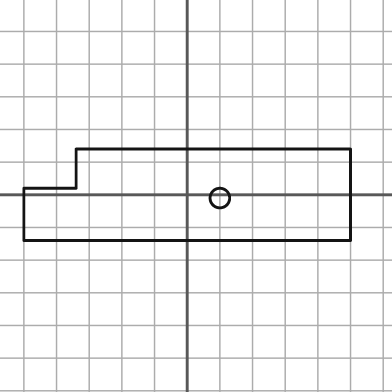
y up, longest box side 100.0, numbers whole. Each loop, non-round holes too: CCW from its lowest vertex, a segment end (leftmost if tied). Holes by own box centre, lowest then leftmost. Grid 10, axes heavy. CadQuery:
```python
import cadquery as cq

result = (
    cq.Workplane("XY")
    .moveTo(-50.0, -14.0)
    .lineTo(50.0, -14.0)
    .lineTo(50.0, 14.0)
    .lineTo(-34.0, 14.0)
    .lineTo(-34.0, 2.0)
    .lineTo(-50.0, 2.0)
    .close()
    .moveTo(10.0, -1.0)
    .circle(3.0)
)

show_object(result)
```